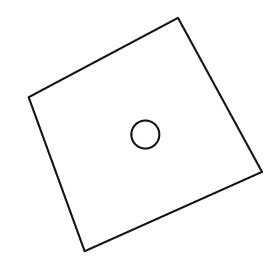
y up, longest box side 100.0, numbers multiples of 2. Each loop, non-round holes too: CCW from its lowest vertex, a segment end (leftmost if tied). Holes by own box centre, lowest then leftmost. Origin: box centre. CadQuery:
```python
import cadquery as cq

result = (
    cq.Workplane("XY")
    .moveTo(-26.0, -50.0)
    .lineTo(50.0, -16.0)
    .lineTo(14.0, 50.0)
    .lineTo(-50.0, 16.0)
    .close()
    .moveTo(0.0, 0.0)
    .circle(6.0)
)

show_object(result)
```